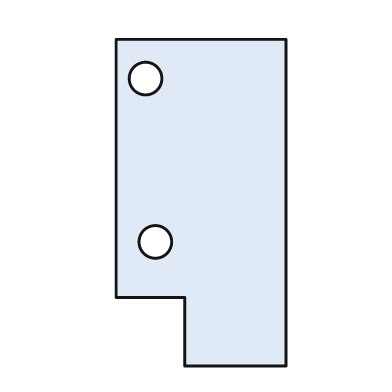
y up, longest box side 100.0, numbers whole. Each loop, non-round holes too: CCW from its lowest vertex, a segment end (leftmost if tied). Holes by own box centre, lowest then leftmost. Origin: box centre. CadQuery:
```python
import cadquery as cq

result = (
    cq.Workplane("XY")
    .moveTo(-5.0, -50.0)
    .lineTo(26.0, -50.0)
    .lineTo(26.0, 50.0)
    .lineTo(-26.0, 50.0)
    .lineTo(-26.0, -29.0)
    .lineTo(-5.0, -29.0)
    .close()
    .moveTo(-14.0, -12.0)
    .circle(5.0)
    .moveTo(-17.0, 38.0)
    .circle(5.0)
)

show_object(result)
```